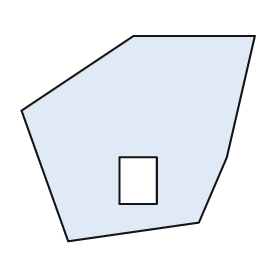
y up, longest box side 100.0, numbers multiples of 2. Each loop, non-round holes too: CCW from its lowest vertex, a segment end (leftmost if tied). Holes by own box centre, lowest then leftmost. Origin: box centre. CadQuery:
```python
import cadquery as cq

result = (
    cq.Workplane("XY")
    .moveTo(-30.0, -44.0)
    .lineTo(26.0, -36.0)
    .lineTo(38.0, -8.0)
    .lineTo(50.0, 44.0)
    .lineTo(-2.0, 44.0)
    .lineTo(-50.0, 12.0)
    .close()
    .moveTo(-8.0, -28.0)
    .lineTo(8.0, -28.0)
    .lineTo(8.0, -8.0)
    .lineTo(-8.0, -8.0)
    .close()
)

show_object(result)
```